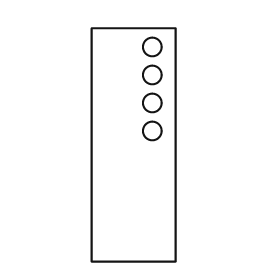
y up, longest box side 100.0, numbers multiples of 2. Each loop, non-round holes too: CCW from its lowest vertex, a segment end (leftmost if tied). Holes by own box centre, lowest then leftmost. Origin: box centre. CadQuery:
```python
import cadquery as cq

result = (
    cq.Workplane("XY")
    .moveTo(-18.0, -50.0)
    .lineTo(18.0, -50.0)
    .lineTo(18.0, 50.0)
    .lineTo(-18.0, 50.0)
    .close()
    .moveTo(8.0, 6.0)
    .circle(4.0)
    .moveTo(8.0, 18.0)
    .circle(4.0)
    .moveTo(8.0, 30.0)
    .circle(4.0)
    .moveTo(8.0, 42.0)
    .circle(4.0)
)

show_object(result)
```